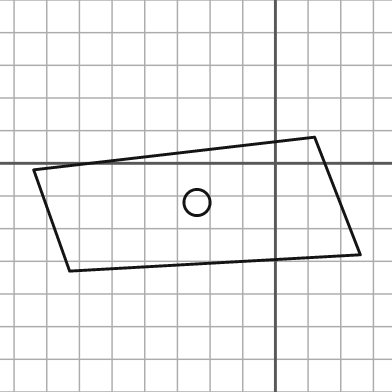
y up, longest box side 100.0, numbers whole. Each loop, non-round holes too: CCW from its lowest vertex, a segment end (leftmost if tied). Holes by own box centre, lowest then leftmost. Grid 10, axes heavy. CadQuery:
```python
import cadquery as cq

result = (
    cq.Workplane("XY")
    .moveTo(-63.0, -33.0)
    .lineTo(26.0, -28.0)
    .lineTo(12.0, 8.0)
    .lineTo(-74.0, -2.0)
    .close()
    .moveTo(-24.0, -12.0)
    .circle(4.0)
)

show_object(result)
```